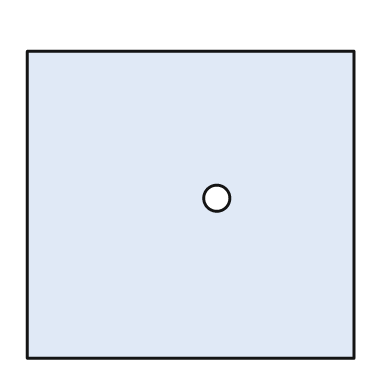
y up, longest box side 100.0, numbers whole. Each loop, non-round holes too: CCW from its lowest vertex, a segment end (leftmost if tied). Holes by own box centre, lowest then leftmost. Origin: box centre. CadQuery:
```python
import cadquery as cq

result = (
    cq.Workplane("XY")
    .moveTo(-50.0, -47.0)
    .lineTo(50.0, -47.0)
    .lineTo(50.0, 47.0)
    .lineTo(-50.0, 47.0)
    .close()
    .moveTo(8.0, 2.0)
    .circle(4.0)
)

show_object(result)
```